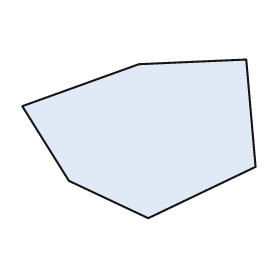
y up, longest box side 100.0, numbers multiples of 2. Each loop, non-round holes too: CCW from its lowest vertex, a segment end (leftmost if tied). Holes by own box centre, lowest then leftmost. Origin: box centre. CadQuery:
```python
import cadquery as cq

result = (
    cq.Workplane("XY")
    .moveTo(4.0, -34.0)
    .lineTo(50.0, -12.0)
    .lineTo(46.0, 34.0)
    .lineTo(0.0, 32.0)
    .lineTo(-50.0, 14.0)
    .lineTo(-30.0, -18.0)
    .close()
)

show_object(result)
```